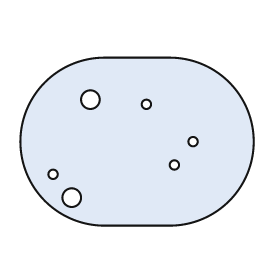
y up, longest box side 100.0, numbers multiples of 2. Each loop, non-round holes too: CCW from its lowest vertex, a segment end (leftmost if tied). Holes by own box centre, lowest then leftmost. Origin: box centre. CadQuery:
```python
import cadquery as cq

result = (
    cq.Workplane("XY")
    .moveTo(-14.0, -36.0)
    .lineTo(14.0, -36.0)
    .threePointArc((50.0, 0.0), (14.0, 36.0))
    .lineTo(-14.0, 36.0)
    .threePointArc((-50.0, 0.0), (-14.0, -36.0))
    .close()
    .moveTo(-28.0, -24.0)
    .circle(4.0)
    .moveTo(-36.0, -14.0)
    .circle(2.0)
    .moveTo(16.0, -10.0)
    .circle(2.0)
    .moveTo(24.0, 0.0)
    .circle(2.0)
    .moveTo(4.0, 16.0)
    .circle(2.0)
    .moveTo(-20.0, 18.0)
    .circle(4.0)
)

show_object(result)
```